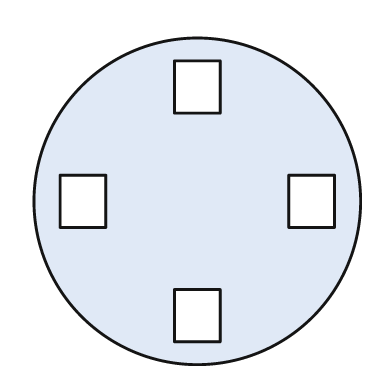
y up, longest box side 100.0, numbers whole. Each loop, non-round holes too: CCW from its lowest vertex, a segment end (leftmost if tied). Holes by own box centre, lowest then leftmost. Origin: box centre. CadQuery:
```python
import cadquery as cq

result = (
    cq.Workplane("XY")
    .moveTo(0.0, 0.0)
    .circle(50.0)
    .moveTo(-7.0, -43.0)
    .lineTo(7.0, -43.0)
    .lineTo(7.0, -27.0)
    .lineTo(-7.0, -27.0)
    .close()
    .moveTo(-42.0, -8.0)
    .lineTo(-28.0, -8.0)
    .lineTo(-28.0, 8.0)
    .lineTo(-42.0, 8.0)
    .close()
    .moveTo(28.0, -8.0)
    .lineTo(42.0, -8.0)
    .lineTo(42.0, 8.0)
    .lineTo(28.0, 8.0)
    .close()
    .moveTo(-7.0, 27.0)
    .lineTo(7.0, 27.0)
    .lineTo(7.0, 43.0)
    .lineTo(-7.0, 43.0)
    .close()
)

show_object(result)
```